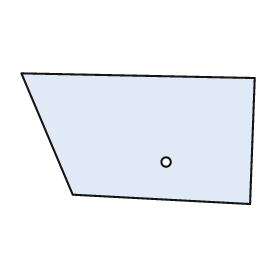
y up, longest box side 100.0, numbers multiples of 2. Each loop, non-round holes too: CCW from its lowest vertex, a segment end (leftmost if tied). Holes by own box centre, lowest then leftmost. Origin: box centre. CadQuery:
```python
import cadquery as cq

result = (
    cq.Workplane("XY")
    .moveTo(48.0, -28.0)
    .lineTo(50.0, 26.0)
    .lineTo(-50.0, 28.0)
    .lineTo(-28.0, -24.0)
    .close()
    .moveTo(12.0, -10.0)
    .circle(2.0)
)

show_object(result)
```